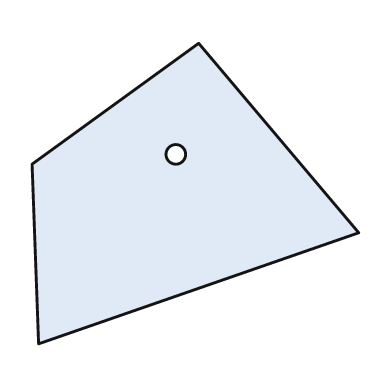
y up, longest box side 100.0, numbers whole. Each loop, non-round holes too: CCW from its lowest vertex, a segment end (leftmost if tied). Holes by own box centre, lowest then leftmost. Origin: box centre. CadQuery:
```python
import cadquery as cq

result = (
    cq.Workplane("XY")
    .moveTo(-48.0, -46.0)
    .lineTo(50.0, -12.0)
    .lineTo(1.0, 46.0)
    .lineTo(-50.0, 9.0)
    .close()
    .moveTo(-6.0, 12.0)
    .circle(3.0)
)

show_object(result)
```